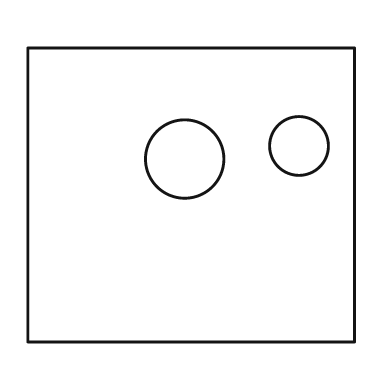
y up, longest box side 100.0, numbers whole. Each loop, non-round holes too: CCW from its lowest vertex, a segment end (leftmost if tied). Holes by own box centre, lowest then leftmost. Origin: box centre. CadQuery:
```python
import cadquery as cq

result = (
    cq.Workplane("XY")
    .moveTo(-50.0, -45.0)
    .lineTo(50.0, -45.0)
    .lineTo(50.0, 45.0)
    .lineTo(-50.0, 45.0)
    .close()
    .moveTo(-2.0, 11.0)
    .circle(12.0)
    .moveTo(33.0, 15.0)
    .circle(9.0)
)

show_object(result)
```